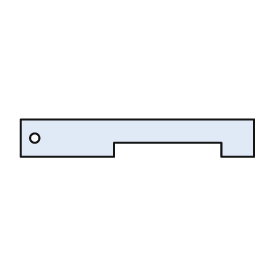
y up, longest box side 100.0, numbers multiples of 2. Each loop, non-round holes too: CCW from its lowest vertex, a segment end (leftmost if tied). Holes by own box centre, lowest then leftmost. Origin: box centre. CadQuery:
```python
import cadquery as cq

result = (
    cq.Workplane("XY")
    .moveTo(-50.0, -8.0)
    .lineTo(-10.0, -8.0)
    .lineTo(-10.0, -2.0)
    .lineTo(36.0, -2.0)
    .lineTo(36.0, -8.0)
    .lineTo(50.0, -8.0)
    .lineTo(50.0, 8.0)
    .lineTo(-50.0, 8.0)
    .close()
    .moveTo(-44.0, 0.0)
    .circle(2.0)
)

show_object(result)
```